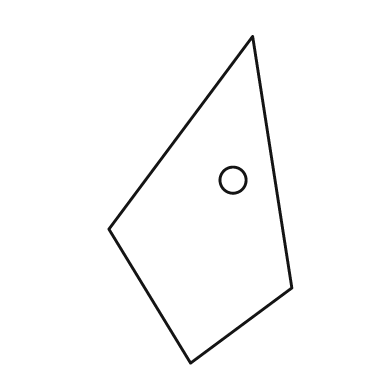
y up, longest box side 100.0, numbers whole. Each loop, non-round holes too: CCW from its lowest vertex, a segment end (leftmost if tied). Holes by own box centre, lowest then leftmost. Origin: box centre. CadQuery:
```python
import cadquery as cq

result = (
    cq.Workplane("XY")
    .moveTo(-3.0, -50.0)
    .lineTo(28.0, -27.0)
    .lineTo(16.0, 50.0)
    .lineTo(-28.0, -9.0)
    .close()
    .moveTo(10.0, 6.0)
    .circle(4.0)
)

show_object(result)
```